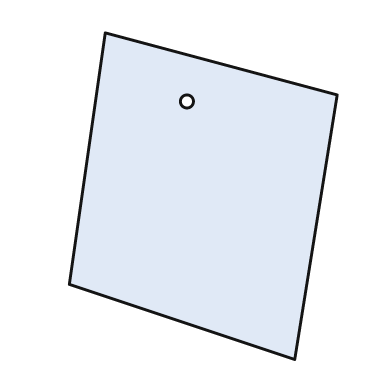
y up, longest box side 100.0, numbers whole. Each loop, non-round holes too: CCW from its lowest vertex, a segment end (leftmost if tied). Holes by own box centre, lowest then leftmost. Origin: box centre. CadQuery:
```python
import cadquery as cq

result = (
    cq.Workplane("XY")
    .moveTo(28.0, -50.0)
    .lineTo(41.0, 31.0)
    .lineTo(-30.0, 50.0)
    .lineTo(-41.0, -27.0)
    .close()
    .moveTo(-5.0, 29.0)
    .circle(2.0)
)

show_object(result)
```